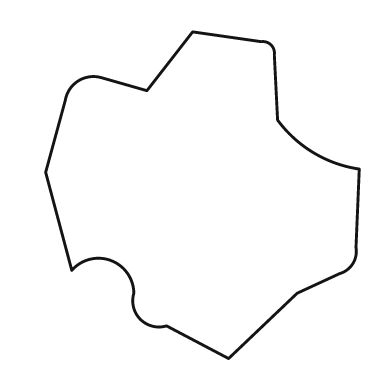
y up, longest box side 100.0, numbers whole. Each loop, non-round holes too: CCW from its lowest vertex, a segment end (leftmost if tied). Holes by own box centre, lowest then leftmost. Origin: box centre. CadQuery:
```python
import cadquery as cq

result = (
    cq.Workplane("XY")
    .moveTo(8.0, -50.0)
    .lineTo(29.0, -30.0)
    .lineTo(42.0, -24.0)
    .threePointArc((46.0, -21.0), (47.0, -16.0))
    .lineTo(48.0, 8.0)
    .threePointArc((34.0, 13.0), (23.0, 23.0))
    .lineTo(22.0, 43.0)
    .threePointArc((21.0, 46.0), (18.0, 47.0))
    .lineTo(-3.0, 50.0)
    .lineTo(-17.0, 32.0)
    .lineTo(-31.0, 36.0)
    .threePointArc((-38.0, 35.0), (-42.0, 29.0))
    .lineTo(-48.0, 7.0)
    .lineTo(-40.0, -23.0)
    .threePointArc((-28.0, -20.0), (-21.0, -30.0))
    .threePointArc((-19.0, -38.0), (-11.0, -40.0))
    .close()
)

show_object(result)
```